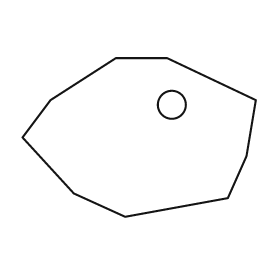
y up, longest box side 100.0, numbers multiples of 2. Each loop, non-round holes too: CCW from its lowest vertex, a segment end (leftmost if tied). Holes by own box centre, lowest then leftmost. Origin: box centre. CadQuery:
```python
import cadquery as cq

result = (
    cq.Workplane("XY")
    .moveTo(-6.0, -34.0)
    .lineTo(38.0, -26.0)
    .lineTo(46.0, -8.0)
    .lineTo(50.0, 16.0)
    .lineTo(12.0, 34.0)
    .lineTo(-10.0, 34.0)
    .lineTo(-38.0, 16.0)
    .lineTo(-50.0, 0.0)
    .lineTo(-28.0, -24.0)
    .close()
    .moveTo(14.0, 14.0)
    .circle(6.0)
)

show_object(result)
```